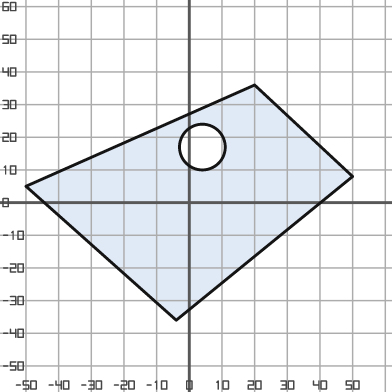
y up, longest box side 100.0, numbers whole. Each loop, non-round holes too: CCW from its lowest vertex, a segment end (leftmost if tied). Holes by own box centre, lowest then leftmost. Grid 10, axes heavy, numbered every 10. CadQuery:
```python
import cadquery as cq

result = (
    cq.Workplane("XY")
    .moveTo(-4.0, -36.0)
    .lineTo(50.0, 8.0)
    .lineTo(20.0, 36.0)
    .lineTo(-50.0, 5.0)
    .close()
    .moveTo(4.0, 17.0)
    .circle(7.0)
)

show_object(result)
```